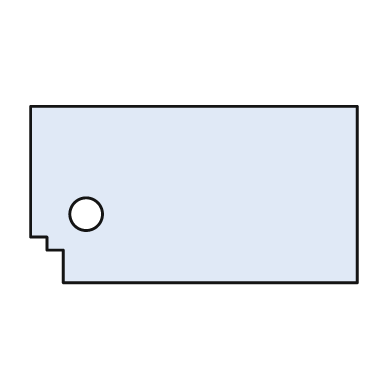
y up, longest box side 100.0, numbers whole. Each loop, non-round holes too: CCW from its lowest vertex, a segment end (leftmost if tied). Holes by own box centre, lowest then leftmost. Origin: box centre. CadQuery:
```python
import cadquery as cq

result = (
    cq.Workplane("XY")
    .moveTo(-40.0, -27.0)
    .lineTo(50.0, -27.0)
    .lineTo(50.0, 27.0)
    .lineTo(-50.0, 27.0)
    .lineTo(-50.0, -13.0)
    .lineTo(-45.0, -13.0)
    .lineTo(-45.0, -17.0)
    .lineTo(-40.0, -17.0)
    .close()
    .moveTo(-33.0, -6.0)
    .circle(5.0)
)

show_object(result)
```